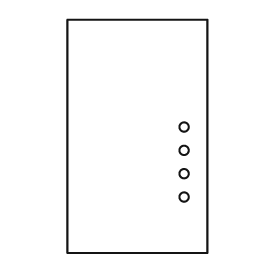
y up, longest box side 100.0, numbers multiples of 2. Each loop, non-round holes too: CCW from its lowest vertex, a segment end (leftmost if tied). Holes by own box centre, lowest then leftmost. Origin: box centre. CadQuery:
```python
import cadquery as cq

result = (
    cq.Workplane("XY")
    .moveTo(-30.0, -50.0)
    .lineTo(30.0, -50.0)
    .lineTo(30.0, 50.0)
    .lineTo(-30.0, 50.0)
    .close()
    .moveTo(20.0, -26.0)
    .circle(2.0)
    .moveTo(20.0, -16.0)
    .circle(2.0)
    .moveTo(20.0, -6.0)
    .circle(2.0)
    .moveTo(20.0, 4.0)
    .circle(2.0)
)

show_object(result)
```